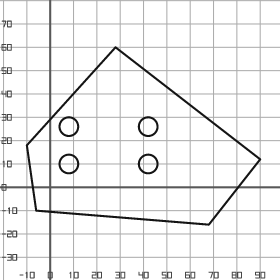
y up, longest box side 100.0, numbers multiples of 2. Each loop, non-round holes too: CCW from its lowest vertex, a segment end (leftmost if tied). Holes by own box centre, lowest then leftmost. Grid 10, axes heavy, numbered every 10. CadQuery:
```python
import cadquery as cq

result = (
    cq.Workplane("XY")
    .moveTo(68.0, -16.0)
    .lineTo(90.0, 12.0)
    .lineTo(28.0, 60.0)
    .lineTo(-10.0, 18.0)
    .lineTo(-6.0, -10.0)
    .close()
    .moveTo(8.0, 10.0)
    .circle(4.0)
    .moveTo(42.0, 10.0)
    .circle(4.0)
    .moveTo(8.0, 26.0)
    .circle(4.0)
    .moveTo(42.0, 26.0)
    .circle(4.0)
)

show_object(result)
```